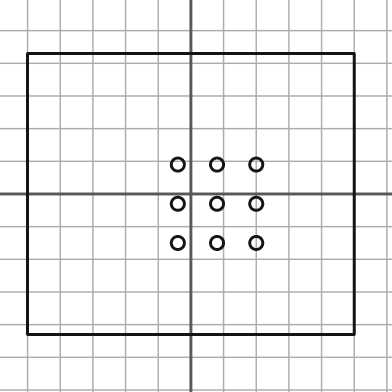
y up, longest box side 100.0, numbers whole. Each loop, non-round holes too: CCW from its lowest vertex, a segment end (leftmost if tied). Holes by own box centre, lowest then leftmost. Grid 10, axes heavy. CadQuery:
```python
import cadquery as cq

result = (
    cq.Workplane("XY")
    .moveTo(-50.0, -43.0)
    .lineTo(50.0, -43.0)
    .lineTo(50.0, 43.0)
    .lineTo(-50.0, 43.0)
    .close()
    .moveTo(-4.0, -15.0)
    .circle(2.0)
    .moveTo(8.0, -15.0)
    .circle(2.0)
    .moveTo(20.0, -15.0)
    .circle(2.0)
    .moveTo(-4.0, -3.0)
    .circle(2.0)
    .moveTo(8.0, -3.0)
    .circle(2.0)
    .moveTo(20.0, -3.0)
    .circle(2.0)
    .moveTo(-4.0, 9.0)
    .circle(2.0)
    .moveTo(8.0, 9.0)
    .circle(2.0)
    .moveTo(20.0, 9.0)
    .circle(2.0)
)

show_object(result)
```